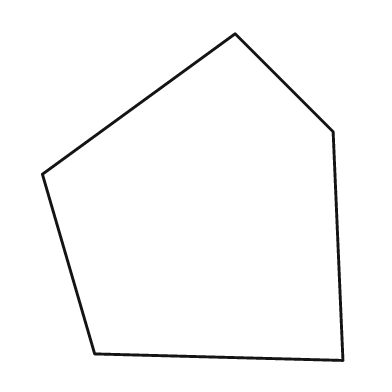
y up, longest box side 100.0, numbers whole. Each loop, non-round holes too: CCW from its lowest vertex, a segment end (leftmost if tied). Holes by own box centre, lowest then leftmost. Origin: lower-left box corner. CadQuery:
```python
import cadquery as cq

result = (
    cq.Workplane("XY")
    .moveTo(92.0, 0.0)
    .lineTo(89.0, 70.0)
    .lineTo(59.0, 100.0)
    .lineTo(0.0, 57.0)
    .lineTo(16.0, 2.0)
    .close()
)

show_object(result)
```